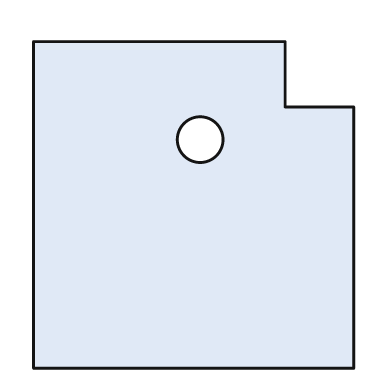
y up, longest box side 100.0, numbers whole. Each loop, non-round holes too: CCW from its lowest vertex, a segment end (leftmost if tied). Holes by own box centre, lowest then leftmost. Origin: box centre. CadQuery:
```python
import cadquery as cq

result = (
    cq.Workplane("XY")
    .moveTo(-49.0, -50.0)
    .lineTo(49.0, -50.0)
    .lineTo(49.0, 30.0)
    .lineTo(28.0, 30.0)
    .lineTo(28.0, 50.0)
    .lineTo(-49.0, 50.0)
    .close()
    .moveTo(2.0, 20.0)
    .circle(7.0)
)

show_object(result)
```